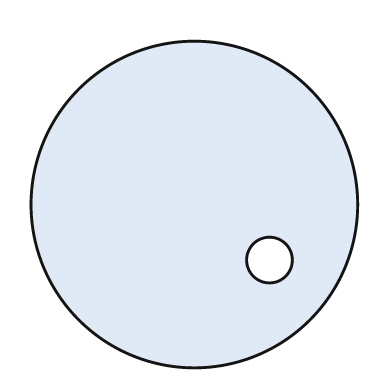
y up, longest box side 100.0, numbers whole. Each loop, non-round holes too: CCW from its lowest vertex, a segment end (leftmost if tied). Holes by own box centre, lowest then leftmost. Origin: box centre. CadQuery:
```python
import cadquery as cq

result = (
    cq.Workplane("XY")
    .moveTo(0.0, 0.0)
    .circle(50.0)
    .moveTo(23.0, -17.0)
    .circle(7.0)
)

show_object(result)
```